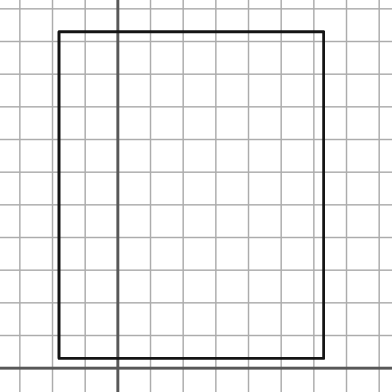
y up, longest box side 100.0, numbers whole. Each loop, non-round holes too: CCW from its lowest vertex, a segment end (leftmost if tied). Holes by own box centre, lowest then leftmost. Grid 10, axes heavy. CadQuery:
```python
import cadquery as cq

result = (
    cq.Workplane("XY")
    .moveTo(-18.0, 3.0)
    .lineTo(63.0, 3.0)
    .lineTo(63.0, 103.0)
    .lineTo(-18.0, 103.0)
    .close()
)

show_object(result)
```